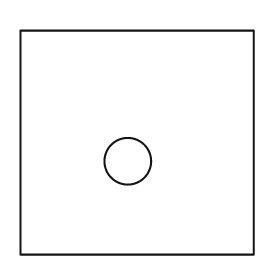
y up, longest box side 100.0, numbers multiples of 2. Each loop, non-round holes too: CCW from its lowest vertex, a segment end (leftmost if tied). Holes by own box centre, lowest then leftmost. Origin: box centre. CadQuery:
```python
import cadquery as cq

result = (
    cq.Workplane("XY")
    .moveTo(-50.0, -48.0)
    .lineTo(50.0, -48.0)
    .lineTo(50.0, 48.0)
    .lineTo(-50.0, 48.0)
    .close()
    .moveTo(-4.0, -8.0)
    .circle(10.0)
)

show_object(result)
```